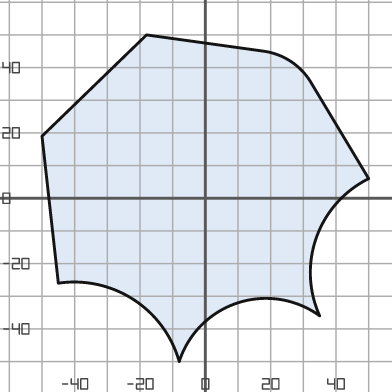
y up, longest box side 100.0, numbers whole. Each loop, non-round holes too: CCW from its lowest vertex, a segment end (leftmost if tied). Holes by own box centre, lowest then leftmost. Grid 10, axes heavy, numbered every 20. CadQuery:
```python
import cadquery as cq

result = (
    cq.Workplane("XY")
    .moveTo(-8.0, -50.0)
    .threePointArc((10.0, -32.0), (35.0, -36.0))
    .threePointArc((34.0, -12.0), (50.0, 6.0))
    .lineTo(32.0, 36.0)
    .threePointArc((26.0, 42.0), (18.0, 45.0))
    .lineTo(-18.0, 50.0)
    .lineTo(-50.0, 19.0)
    .lineTo(-45.0, -26.0)
    .threePointArc((-22.0, -31.0), (-8.0, -50.0))
    .close()
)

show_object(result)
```